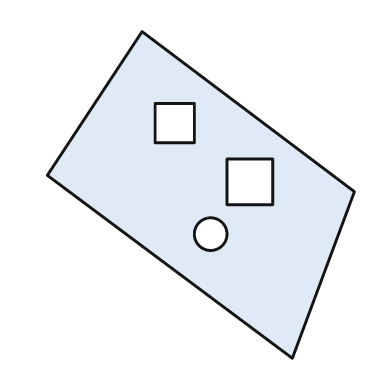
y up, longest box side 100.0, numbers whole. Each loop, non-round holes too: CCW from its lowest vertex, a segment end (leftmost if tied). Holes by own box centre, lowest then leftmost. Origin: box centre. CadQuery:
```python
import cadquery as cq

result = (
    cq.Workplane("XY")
    .moveTo(28.0, -50.0)
    .lineTo(47.0, 1.0)
    .lineTo(-18.0, 50.0)
    .lineTo(-47.0, 6.0)
    .close()
    .moveTo(3.0, -12.0)
    .circle(5.0)
    .moveTo(8.0, -3.0)
    .lineTo(22.0, -3.0)
    .lineTo(22.0, 11.0)
    .lineTo(8.0, 11.0)
    .close()
    .moveTo(-14.0, 16.0)
    .lineTo(-2.0, 16.0)
    .lineTo(-2.0, 28.0)
    .lineTo(-14.0, 28.0)
    .close()
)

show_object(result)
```